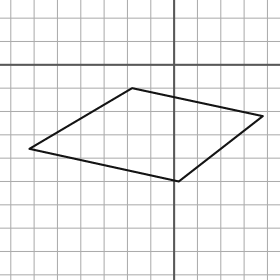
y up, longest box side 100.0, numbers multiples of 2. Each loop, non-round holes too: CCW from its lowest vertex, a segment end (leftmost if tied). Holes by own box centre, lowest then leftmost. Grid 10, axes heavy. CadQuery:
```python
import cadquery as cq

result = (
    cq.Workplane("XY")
    .moveTo(2.0, -50.0)
    .lineTo(38.0, -22.0)
    .lineTo(-18.0, -10.0)
    .lineTo(-62.0, -36.0)
    .close()
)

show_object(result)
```